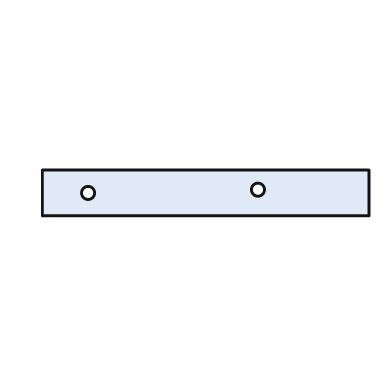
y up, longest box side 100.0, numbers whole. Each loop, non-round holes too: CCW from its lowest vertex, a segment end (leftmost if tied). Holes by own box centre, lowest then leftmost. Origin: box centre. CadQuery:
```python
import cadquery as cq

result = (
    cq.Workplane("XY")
    .moveTo(-50.0, -7.0)
    .lineTo(50.0, -7.0)
    .lineTo(50.0, 7.0)
    .lineTo(-50.0, 7.0)
    .close()
    .moveTo(-36.0, 0.0)
    .circle(2.0)
    .moveTo(16.0, 1.0)
    .circle(2.0)
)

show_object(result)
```